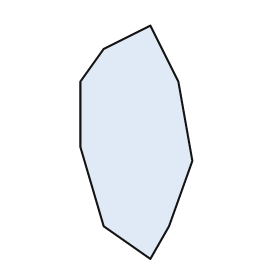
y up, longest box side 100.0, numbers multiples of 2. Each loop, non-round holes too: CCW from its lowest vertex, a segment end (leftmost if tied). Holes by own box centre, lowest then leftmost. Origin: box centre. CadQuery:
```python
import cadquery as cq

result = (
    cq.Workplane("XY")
    .moveTo(6.0, -50.0)
    .lineTo(14.0, -36.0)
    .lineTo(24.0, -8.0)
    .lineTo(18.0, 26.0)
    .lineTo(6.0, 50.0)
    .lineTo(-14.0, 40.0)
    .lineTo(-24.0, 26.0)
    .lineTo(-24.0, -2.0)
    .lineTo(-14.0, -36.0)
    .close()
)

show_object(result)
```